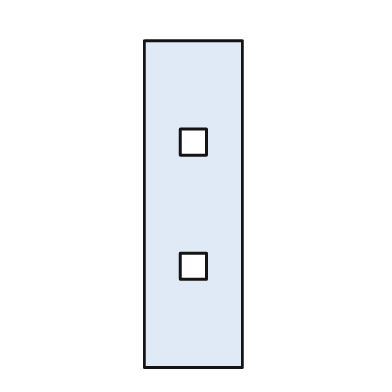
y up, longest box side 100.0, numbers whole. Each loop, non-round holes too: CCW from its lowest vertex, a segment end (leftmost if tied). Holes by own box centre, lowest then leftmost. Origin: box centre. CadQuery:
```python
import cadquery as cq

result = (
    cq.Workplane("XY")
    .moveTo(-15.0, -50.0)
    .lineTo(15.0, -50.0)
    .lineTo(15.0, 50.0)
    .lineTo(-15.0, 50.0)
    .close()
    .moveTo(-4.0, -23.0)
    .lineTo(4.0, -23.0)
    .lineTo(4.0, -15.0)
    .lineTo(-4.0, -15.0)
    .close()
    .moveTo(-4.0, 15.0)
    .lineTo(4.0, 15.0)
    .lineTo(4.0, 23.0)
    .lineTo(-4.0, 23.0)
    .close()
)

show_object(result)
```